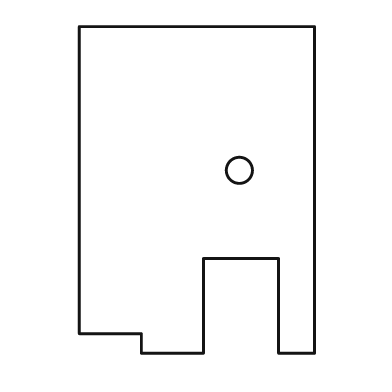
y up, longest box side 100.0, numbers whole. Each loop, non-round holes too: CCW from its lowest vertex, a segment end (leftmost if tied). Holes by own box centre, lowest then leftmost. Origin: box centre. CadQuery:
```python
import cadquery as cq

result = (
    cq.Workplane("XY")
    .moveTo(-17.0, -50.0)
    .lineTo(2.0, -50.0)
    .lineTo(2.0, -21.0)
    .lineTo(25.0, -21.0)
    .lineTo(25.0, -50.0)
    .lineTo(36.0, -50.0)
    .lineTo(36.0, 50.0)
    .lineTo(-36.0, 50.0)
    .lineTo(-36.0, -44.0)
    .lineTo(-17.0, -44.0)
    .close()
    .moveTo(13.0, 6.0)
    .circle(4.0)
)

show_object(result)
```